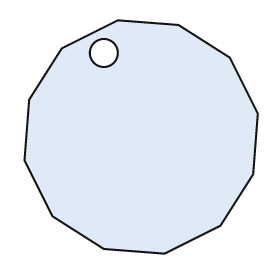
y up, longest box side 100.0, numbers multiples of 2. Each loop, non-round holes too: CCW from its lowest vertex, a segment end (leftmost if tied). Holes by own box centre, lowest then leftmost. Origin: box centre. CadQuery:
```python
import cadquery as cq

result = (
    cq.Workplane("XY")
    .moveTo(10.0, -50.0)
    .lineTo(34.0, -38.0)
    .lineTo(48.0, -16.0)
    .lineTo(50.0, 10.0)
    .lineTo(38.0, 34.0)
    .lineTo(16.0, 48.0)
    .lineTo(-10.0, 50.0)
    .lineTo(-34.0, 38.0)
    .lineTo(-48.0, 16.0)
    .lineTo(-50.0, -10.0)
    .lineTo(-38.0, -34.0)
    .lineTo(-16.0, -48.0)
    .close()
    .moveTo(-16.0, 36.0)
    .circle(6.0)
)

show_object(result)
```